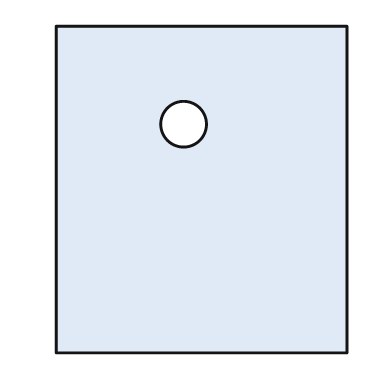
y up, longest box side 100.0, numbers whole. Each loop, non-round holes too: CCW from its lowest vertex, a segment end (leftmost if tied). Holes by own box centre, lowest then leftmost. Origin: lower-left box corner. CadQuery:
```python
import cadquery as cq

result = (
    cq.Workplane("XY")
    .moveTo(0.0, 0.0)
    .lineTo(89.0, 0.0)
    .lineTo(89.0, 100.0)
    .lineTo(0.0, 100.0)
    .close()
    .moveTo(39.0, 70.0)
    .circle(7.0)
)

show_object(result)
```